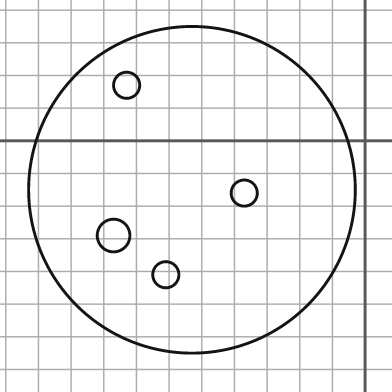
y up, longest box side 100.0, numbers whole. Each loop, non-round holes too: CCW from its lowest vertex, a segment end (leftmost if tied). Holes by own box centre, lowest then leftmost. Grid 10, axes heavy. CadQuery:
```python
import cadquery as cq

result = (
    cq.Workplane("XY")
    .moveTo(-53.0, -15.0)
    .circle(50.0)
    .moveTo(-61.0, -41.0)
    .circle(4.0)
    .moveTo(-77.0, -29.0)
    .circle(5.0)
    .moveTo(-37.0, -16.0)
    .circle(4.0)
    .moveTo(-73.0, 17.0)
    .circle(4.0)
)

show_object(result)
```